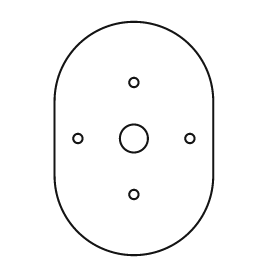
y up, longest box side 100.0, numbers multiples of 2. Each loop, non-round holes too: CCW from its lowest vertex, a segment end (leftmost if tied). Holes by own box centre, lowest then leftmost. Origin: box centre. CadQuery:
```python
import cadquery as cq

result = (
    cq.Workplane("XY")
    .moveTo(-34.0, -16.0)
    .threePointArc((0.0, -50.0), (34.0, -16.0))
    .lineTo(34.0, 16.0)
    .threePointArc((0.0, 50.0), (-34.0, 16.0))
    .close()
    .moveTo(0.0, -24.0)
    .circle(2.0)
    .moveTo(-24.0, 0.0)
    .circle(2.0)
    .moveTo(0.0, 0.0)
    .circle(6.0)
    .moveTo(24.0, 0.0)
    .circle(2.0)
    .moveTo(0.0, 24.0)
    .circle(2.0)
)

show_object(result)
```